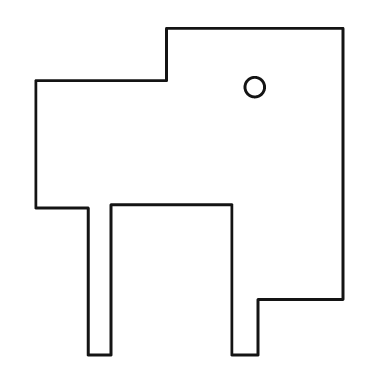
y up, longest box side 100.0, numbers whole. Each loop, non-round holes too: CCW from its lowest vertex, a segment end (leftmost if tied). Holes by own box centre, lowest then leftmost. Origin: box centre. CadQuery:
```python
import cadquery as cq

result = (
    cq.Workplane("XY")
    .moveTo(-31.0, -50.0)
    .lineTo(-24.0, -50.0)
    .lineTo(-24.0, -4.0)
    .lineTo(13.0, -4.0)
    .lineTo(13.0, -50.0)
    .lineTo(21.0, -50.0)
    .lineTo(21.0, -33.0)
    .lineTo(47.0, -33.0)
    .lineTo(47.0, 50.0)
    .lineTo(-7.0, 50.0)
    .lineTo(-7.0, 34.0)
    .lineTo(-47.0, 34.0)
    .lineTo(-47.0, -5.0)
    .lineTo(-31.0, -5.0)
    .close()
    .moveTo(20.0, 32.0)
    .circle(3.0)
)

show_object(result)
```